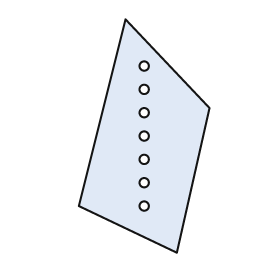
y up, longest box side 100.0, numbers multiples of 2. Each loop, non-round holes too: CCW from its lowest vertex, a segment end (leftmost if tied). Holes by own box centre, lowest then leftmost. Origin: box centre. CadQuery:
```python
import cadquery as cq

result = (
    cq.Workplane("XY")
    .moveTo(14.0, -50.0)
    .lineTo(28.0, 12.0)
    .lineTo(-8.0, 50.0)
    .lineTo(-28.0, -30.0)
    .close()
    .moveTo(0.0, -30.0)
    .circle(2.0)
    .moveTo(0.0, -20.0)
    .circle(2.0)
    .moveTo(0.0, -10.0)
    .circle(2.0)
    .moveTo(0.0, 0.0)
    .circle(2.0)
    .moveTo(0.0, 10.0)
    .circle(2.0)
    .moveTo(0.0, 20.0)
    .circle(2.0)
    .moveTo(0.0, 30.0)
    .circle(2.0)
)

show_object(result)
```